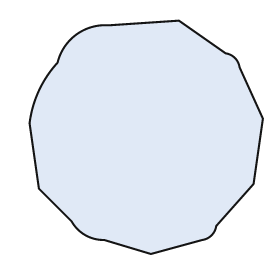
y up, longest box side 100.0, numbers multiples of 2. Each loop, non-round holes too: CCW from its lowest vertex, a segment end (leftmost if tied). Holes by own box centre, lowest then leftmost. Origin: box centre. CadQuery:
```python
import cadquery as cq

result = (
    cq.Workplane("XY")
    .moveTo(2.0, -50.0)
    .lineTo(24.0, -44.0)
    .threePointArc((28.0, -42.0), (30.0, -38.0))
    .lineTo(46.0, -20.0)
    .lineTo(50.0, 8.0)
    .lineTo(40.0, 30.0)
    .threePointArc((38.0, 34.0), (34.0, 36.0))
    .lineTo(14.0, 50.0)
    .lineTo(-16.0, 48.0)
    .threePointArc((-30.0, 44.0), (-38.0, 32.0))
    .threePointArc((-46.0, 20.0), (-50.0, 6.0))
    .lineTo(-46.0, -22.0)
    .lineTo(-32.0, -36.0)
    .threePointArc((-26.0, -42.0), (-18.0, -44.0))
    .close()
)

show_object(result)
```